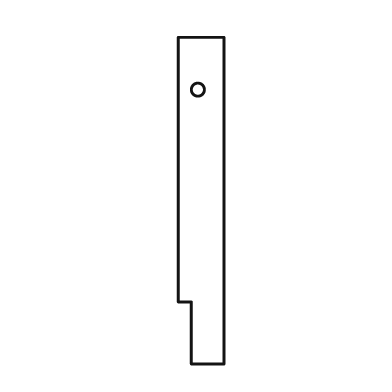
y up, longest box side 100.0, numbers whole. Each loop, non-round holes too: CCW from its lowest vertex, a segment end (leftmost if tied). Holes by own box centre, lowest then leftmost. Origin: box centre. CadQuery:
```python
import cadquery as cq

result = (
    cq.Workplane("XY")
    .moveTo(-3.0, -50.0)
    .lineTo(7.0, -50.0)
    .lineTo(7.0, 50.0)
    .lineTo(-7.0, 50.0)
    .lineTo(-7.0, -31.0)
    .lineTo(-3.0, -31.0)
    .close()
    .moveTo(-1.0, 34.0)
    .circle(2.0)
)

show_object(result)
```